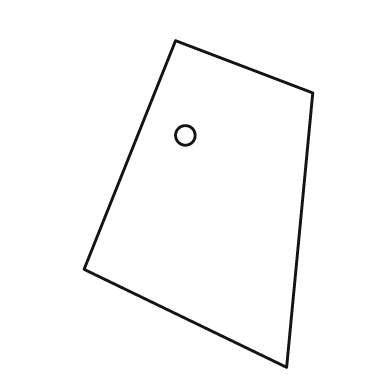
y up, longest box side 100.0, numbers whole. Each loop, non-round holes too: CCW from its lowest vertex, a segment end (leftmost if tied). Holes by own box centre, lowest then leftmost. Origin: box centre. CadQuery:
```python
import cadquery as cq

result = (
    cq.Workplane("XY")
    .moveTo(27.0, -50.0)
    .lineTo(35.0, 34.0)
    .lineTo(-7.0, 50.0)
    .lineTo(-35.0, -20.0)
    .close()
    .moveTo(-4.0, 21.0)
    .circle(3.0)
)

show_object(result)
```